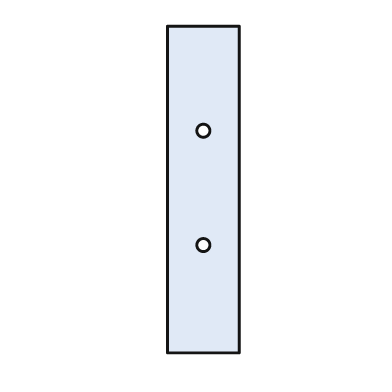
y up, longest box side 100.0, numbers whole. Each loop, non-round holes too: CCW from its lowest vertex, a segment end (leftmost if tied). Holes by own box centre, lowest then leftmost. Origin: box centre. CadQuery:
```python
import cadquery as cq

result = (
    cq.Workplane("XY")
    .moveTo(-11.0, -50.0)
    .lineTo(11.0, -50.0)
    .lineTo(11.0, 50.0)
    .lineTo(-11.0, 50.0)
    .close()
    .moveTo(0.0, -17.0)
    .circle(2.0)
    .moveTo(0.0, 18.0)
    .circle(2.0)
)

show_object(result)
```